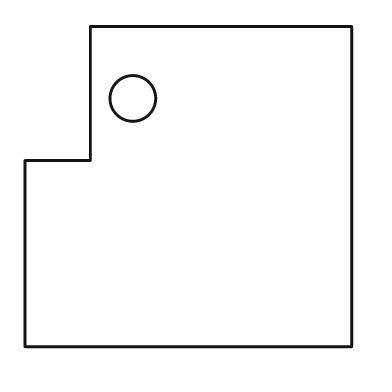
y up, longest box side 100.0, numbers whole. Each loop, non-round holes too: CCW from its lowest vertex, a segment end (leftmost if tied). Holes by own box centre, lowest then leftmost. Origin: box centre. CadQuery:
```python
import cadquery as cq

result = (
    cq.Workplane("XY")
    .moveTo(-50.0, -49.0)
    .lineTo(50.0, -49.0)
    .lineTo(50.0, 49.0)
    .lineTo(-30.0, 49.0)
    .lineTo(-30.0, 8.0)
    .lineTo(-50.0, 8.0)
    .close()
    .moveTo(-17.0, 27.0)
    .circle(7.0)
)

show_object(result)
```